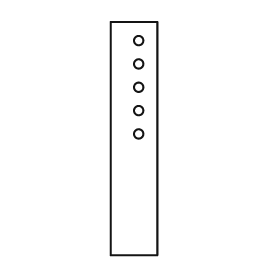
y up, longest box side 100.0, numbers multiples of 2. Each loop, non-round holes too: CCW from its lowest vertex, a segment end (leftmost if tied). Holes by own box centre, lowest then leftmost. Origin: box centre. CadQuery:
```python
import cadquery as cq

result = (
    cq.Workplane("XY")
    .moveTo(-10.0, -50.0)
    .lineTo(10.0, -50.0)
    .lineTo(10.0, 50.0)
    .lineTo(-10.0, 50.0)
    .close()
    .moveTo(2.0, 2.0)
    .circle(2.0)
    .moveTo(2.0, 12.0)
    .circle(2.0)
    .moveTo(2.0, 22.0)
    .circle(2.0)
    .moveTo(2.0, 32.0)
    .circle(2.0)
    .moveTo(2.0, 42.0)
    .circle(2.0)
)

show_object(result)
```